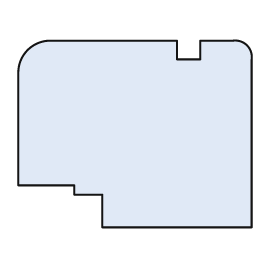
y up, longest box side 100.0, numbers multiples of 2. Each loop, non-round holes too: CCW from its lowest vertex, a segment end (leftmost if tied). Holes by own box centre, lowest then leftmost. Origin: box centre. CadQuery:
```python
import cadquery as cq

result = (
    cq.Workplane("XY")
    .moveTo(-14.0, -40.0)
    .lineTo(50.0, -40.0)
    .lineTo(50.0, 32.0)
    .threePointArc((48.0, 38.0), (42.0, 40.0))
    .lineTo(28.0, 40.0)
    .lineTo(28.0, 32.0)
    .lineTo(18.0, 32.0)
    .lineTo(18.0, 40.0)
    .lineTo(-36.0, 40.0)
    .threePointArc((-46.0, 36.0), (-50.0, 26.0))
    .lineTo(-50.0, -22.0)
    .lineTo(-26.0, -22.0)
    .lineTo(-26.0, -26.0)
    .lineTo(-14.0, -26.0)
    .close()
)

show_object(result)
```